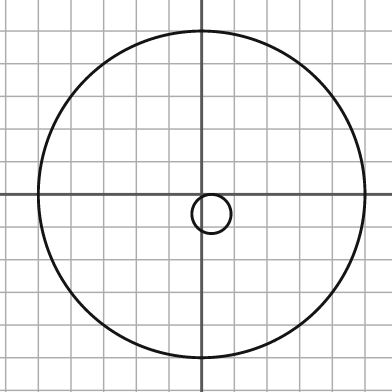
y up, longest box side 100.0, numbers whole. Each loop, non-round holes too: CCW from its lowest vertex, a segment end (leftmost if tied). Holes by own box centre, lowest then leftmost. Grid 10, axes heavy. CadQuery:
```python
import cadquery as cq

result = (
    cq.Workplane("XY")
    .moveTo(0.0, 0.0)
    .circle(50.0)
    .moveTo(3.0, -6.0)
    .circle(6.0)
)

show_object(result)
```